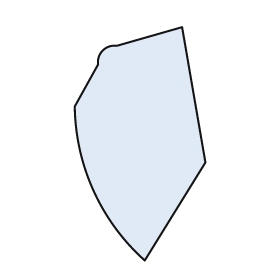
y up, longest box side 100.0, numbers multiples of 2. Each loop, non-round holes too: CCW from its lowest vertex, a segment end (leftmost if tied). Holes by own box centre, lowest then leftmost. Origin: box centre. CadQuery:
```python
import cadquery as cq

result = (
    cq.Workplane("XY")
    .moveTo(2.0, -50.0)
    .lineTo(28.0, -8.0)
    .lineTo(18.0, 50.0)
    .lineTo(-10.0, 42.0)
    .threePointArc((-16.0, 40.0), (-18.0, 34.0))
    .lineTo(-28.0, 16.0)
    .threePointArc((-20.0, -20.0), (2.0, -50.0))
    .close()
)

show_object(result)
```